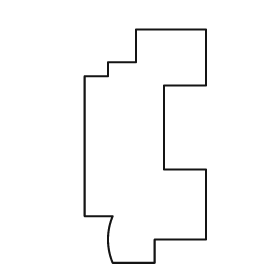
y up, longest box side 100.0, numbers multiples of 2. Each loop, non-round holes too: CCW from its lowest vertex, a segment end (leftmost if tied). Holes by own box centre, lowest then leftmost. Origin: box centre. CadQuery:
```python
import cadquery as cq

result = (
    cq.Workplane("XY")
    .moveTo(-14.0, -50.0)
    .lineTo(4.0, -50.0)
    .lineTo(4.0, -40.0)
    .lineTo(26.0, -40.0)
    .lineTo(26.0, -10.0)
    .lineTo(8.0, -10.0)
    .lineTo(8.0, 26.0)
    .lineTo(26.0, 26.0)
    .lineTo(26.0, 50.0)
    .lineTo(-4.0, 50.0)
    .lineTo(-4.0, 36.0)
    .lineTo(-16.0, 36.0)
    .lineTo(-16.0, 30.0)
    .lineTo(-26.0, 30.0)
    .lineTo(-26.0, -30.0)
    .lineTo(-14.0, -30.0)
    .threePointArc((-16.0, -40.0), (-14.0, -50.0))
    .close()
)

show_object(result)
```